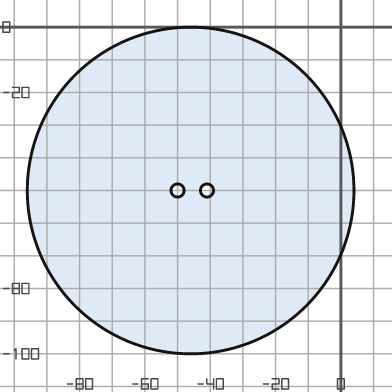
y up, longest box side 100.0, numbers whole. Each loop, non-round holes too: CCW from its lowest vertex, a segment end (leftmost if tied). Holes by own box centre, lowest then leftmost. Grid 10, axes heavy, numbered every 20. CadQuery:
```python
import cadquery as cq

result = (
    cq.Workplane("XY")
    .moveTo(-46.0, -50.0)
    .circle(50.0)
    .moveTo(-50.0, -50.0)
    .circle(2.0)
    .moveTo(-41.0, -50.0)
    .circle(2.0)
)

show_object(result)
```